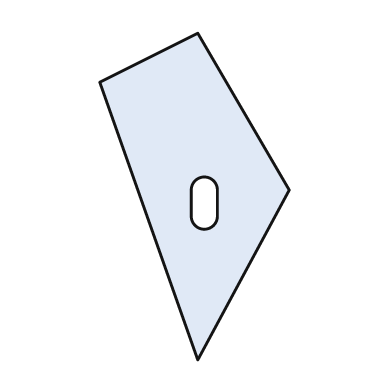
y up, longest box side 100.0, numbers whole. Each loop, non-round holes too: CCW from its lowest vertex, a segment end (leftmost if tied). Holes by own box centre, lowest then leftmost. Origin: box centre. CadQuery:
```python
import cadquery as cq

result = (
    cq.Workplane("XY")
    .moveTo(1.0, -50.0)
    .lineTo(29.0, 2.0)
    .lineTo(1.0, 50.0)
    .lineTo(-29.0, 35.0)
    .close()
    .moveTo(-1.0, -6.0)
    .threePointArc((3.0, -10.0), (7.0, -6.0))
    .lineTo(7.0, 2.0)
    .threePointArc((3.0, 6.0), (-1.0, 2.0))
    .close()
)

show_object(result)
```